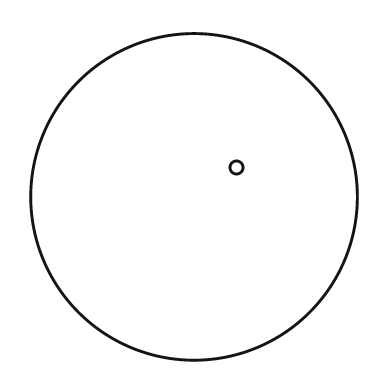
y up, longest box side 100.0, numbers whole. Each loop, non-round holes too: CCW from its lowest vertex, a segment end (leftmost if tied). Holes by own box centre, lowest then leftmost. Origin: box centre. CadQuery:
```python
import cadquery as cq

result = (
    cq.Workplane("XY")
    .moveTo(0.0, 0.0)
    .circle(50.0)
    .moveTo(13.0, 9.0)
    .circle(2.0)
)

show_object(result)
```